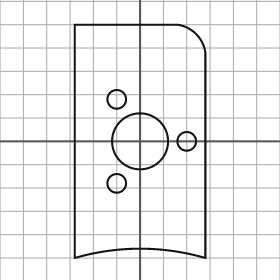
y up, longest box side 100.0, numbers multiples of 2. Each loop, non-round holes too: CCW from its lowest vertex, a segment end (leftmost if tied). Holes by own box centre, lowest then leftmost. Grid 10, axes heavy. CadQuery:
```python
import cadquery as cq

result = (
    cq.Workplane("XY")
    .moveTo(-28.0, -50.0)
    .threePointArc((0.0, -46.0), (28.0, -50.0))
    .lineTo(28.0, 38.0)
    .threePointArc((24.0, 46.0), (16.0, 50.0))
    .lineTo(-28.0, 50.0)
    .close()
    .moveTo(-10.0, -18.0)
    .circle(4.0)
    .moveTo(0.0, 0.0)
    .circle(12.0)
    .moveTo(20.0, 0.0)
    .circle(4.0)
    .moveTo(-10.0, 18.0)
    .circle(4.0)
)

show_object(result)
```